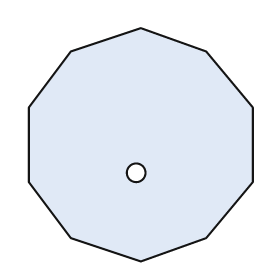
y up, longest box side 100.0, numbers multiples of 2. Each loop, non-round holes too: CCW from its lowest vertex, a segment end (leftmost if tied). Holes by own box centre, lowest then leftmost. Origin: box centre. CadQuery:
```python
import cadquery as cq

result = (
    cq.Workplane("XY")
    .moveTo(0.0, -50.0)
    .lineTo(28.0, -40.0)
    .lineTo(48.0, -16.0)
    .lineTo(48.0, 16.0)
    .lineTo(28.0, 40.0)
    .lineTo(0.0, 50.0)
    .lineTo(-30.0, 40.0)
    .lineTo(-48.0, 16.0)
    .lineTo(-48.0, -16.0)
    .lineTo(-30.0, -40.0)
    .close()
    .moveTo(-2.0, -12.0)
    .circle(4.0)
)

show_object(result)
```